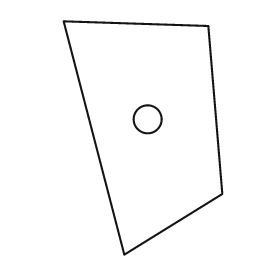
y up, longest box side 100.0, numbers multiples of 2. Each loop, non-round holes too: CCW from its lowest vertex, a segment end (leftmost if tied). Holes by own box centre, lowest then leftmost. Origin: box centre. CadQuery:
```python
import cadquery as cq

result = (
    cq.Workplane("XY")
    .moveTo(-8.0, -50.0)
    .lineTo(34.0, -24.0)
    .lineTo(28.0, 48.0)
    .lineTo(-34.0, 50.0)
    .close()
    .moveTo(2.0, 8.0)
    .circle(6.0)
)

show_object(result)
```